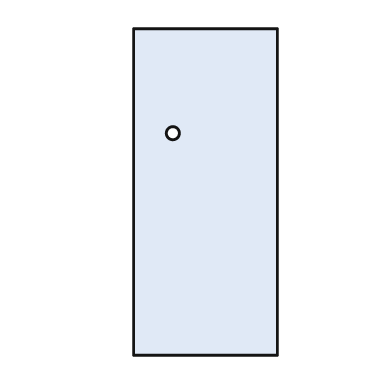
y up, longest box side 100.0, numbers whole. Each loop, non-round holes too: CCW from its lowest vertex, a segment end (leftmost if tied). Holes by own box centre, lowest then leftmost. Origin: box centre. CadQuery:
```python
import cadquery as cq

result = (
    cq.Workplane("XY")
    .moveTo(-22.0, -50.0)
    .lineTo(22.0, -50.0)
    .lineTo(22.0, 50.0)
    .lineTo(-22.0, 50.0)
    .close()
    .moveTo(-10.0, 18.0)
    .circle(2.0)
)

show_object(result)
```